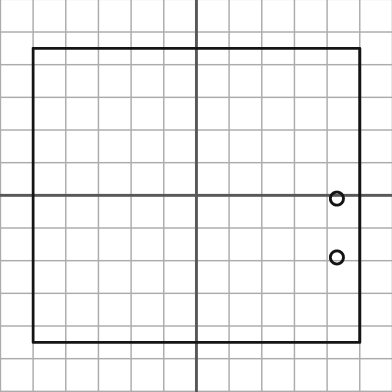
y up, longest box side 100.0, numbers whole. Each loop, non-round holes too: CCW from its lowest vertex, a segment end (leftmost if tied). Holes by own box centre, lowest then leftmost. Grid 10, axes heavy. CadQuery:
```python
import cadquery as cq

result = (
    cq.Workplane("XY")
    .moveTo(-50.0, -45.0)
    .lineTo(50.0, -45.0)
    .lineTo(50.0, 45.0)
    .lineTo(-50.0, 45.0)
    .close()
    .moveTo(43.0, -19.0)
    .circle(2.0)
    .moveTo(43.0, -1.0)
    .circle(2.0)
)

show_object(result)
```